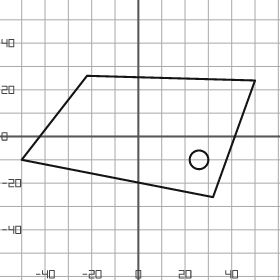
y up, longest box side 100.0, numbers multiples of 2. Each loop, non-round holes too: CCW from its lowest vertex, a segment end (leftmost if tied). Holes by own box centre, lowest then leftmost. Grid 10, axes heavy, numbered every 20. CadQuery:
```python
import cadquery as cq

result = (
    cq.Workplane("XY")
    .moveTo(32.0, -26.0)
    .lineTo(50.0, 24.0)
    .lineTo(-22.0, 26.0)
    .lineTo(-50.0, -10.0)
    .close()
    .moveTo(26.0, -10.0)
    .circle(4.0)
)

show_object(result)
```